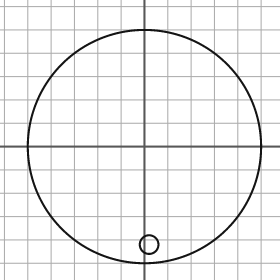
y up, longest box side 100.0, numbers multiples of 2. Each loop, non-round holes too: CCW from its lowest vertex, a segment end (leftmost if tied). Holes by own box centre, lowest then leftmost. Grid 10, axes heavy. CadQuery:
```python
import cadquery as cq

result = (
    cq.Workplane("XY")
    .moveTo(0.0, 0.0)
    .circle(50.0)
    .moveTo(2.0, -42.0)
    .circle(4.0)
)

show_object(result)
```